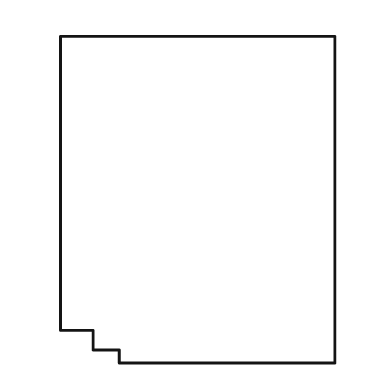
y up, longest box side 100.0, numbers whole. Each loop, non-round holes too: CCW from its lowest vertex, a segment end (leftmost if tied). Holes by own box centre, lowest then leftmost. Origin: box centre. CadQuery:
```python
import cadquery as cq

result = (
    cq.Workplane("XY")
    .moveTo(-24.0, -50.0)
    .lineTo(42.0, -50.0)
    .lineTo(42.0, 50.0)
    .lineTo(-42.0, 50.0)
    .lineTo(-42.0, -40.0)
    .lineTo(-32.0, -40.0)
    .lineTo(-32.0, -46.0)
    .lineTo(-24.0, -46.0)
    .close()
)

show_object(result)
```